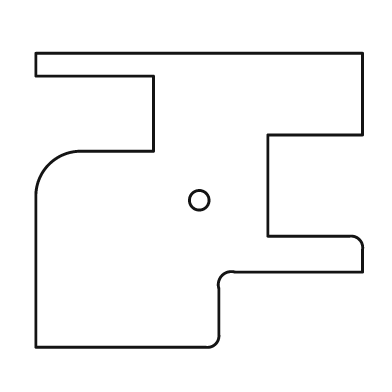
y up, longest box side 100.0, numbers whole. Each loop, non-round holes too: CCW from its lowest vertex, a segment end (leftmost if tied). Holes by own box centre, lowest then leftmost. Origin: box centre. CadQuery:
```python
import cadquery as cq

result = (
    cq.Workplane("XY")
    .moveTo(-50.0, -45.0)
    .lineTo(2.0, -45.0)
    .threePointArc((5.0, -44.0), (6.0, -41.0))
    .lineTo(6.0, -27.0)
    .threePointArc((7.0, -23.0), (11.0, -22.0))
    .lineTo(50.0, -22.0)
    .lineTo(50.0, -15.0)
    .threePointArc((49.0, -12.0), (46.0, -11.0))
    .lineTo(21.0, -11.0)
    .lineTo(21.0, 20.0)
    .lineTo(50.0, 20.0)
    .lineTo(50.0, 45.0)
    .lineTo(-50.0, 45.0)
    .lineTo(-50.0, 38.0)
    .lineTo(-14.0, 38.0)
    .lineTo(-14.0, 15.0)
    .lineTo(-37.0, 15.0)
    .threePointArc((-46.0, 11.0), (-50.0, 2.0))
    .close()
    .moveTo(0.0, 0.0)
    .circle(3.0)
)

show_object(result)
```